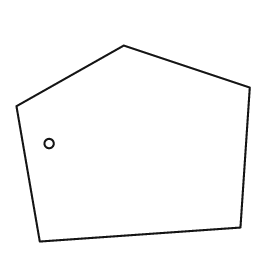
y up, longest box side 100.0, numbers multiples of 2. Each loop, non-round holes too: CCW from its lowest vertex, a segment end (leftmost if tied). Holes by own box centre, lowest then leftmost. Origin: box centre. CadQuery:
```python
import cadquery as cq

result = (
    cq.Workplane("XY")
    .moveTo(-40.0, -42.0)
    .lineTo(46.0, -36.0)
    .lineTo(50.0, 24.0)
    .lineTo(-4.0, 42.0)
    .lineTo(-50.0, 16.0)
    .close()
    .moveTo(-36.0, 0.0)
    .circle(2.0)
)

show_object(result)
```